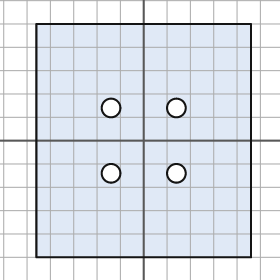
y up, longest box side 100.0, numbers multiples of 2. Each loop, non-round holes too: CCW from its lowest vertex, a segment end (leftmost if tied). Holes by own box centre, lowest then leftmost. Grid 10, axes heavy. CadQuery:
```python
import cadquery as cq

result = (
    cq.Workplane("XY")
    .moveTo(-46.0, -50.0)
    .lineTo(46.0, -50.0)
    .lineTo(46.0, 50.0)
    .lineTo(-46.0, 50.0)
    .close()
    .moveTo(-14.0, -14.0)
    .circle(4.0)
    .moveTo(14.0, -14.0)
    .circle(4.0)
    .moveTo(-14.0, 14.0)
    .circle(4.0)
    .moveTo(14.0, 14.0)
    .circle(4.0)
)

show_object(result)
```